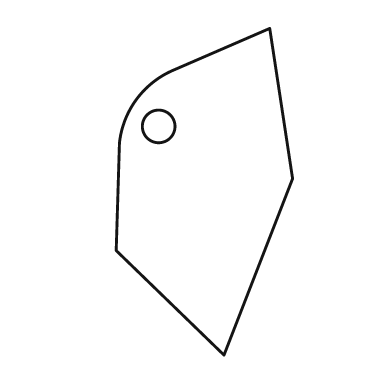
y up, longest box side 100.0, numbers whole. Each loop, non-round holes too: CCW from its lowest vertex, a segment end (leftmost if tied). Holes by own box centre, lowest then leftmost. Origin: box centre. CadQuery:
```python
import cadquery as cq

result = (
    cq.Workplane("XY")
    .moveTo(6.0, -50.0)
    .lineTo(27.0, 4.0)
    .lineTo(20.0, 50.0)
    .lineTo(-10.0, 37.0)
    .threePointArc((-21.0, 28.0), (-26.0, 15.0))
    .lineTo(-27.0, -18.0)
    .close()
    .moveTo(-14.0, 20.0)
    .circle(5.0)
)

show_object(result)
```